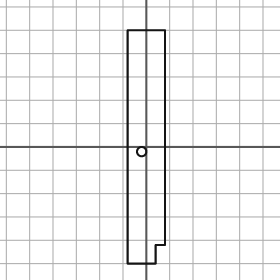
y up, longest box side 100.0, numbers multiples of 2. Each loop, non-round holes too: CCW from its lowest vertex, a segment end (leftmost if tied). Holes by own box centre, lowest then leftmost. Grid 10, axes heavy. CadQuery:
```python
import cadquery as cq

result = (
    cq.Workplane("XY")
    .moveTo(-8.0, -50.0)
    .lineTo(4.0, -50.0)
    .lineTo(4.0, -42.0)
    .lineTo(8.0, -42.0)
    .lineTo(8.0, 50.0)
    .lineTo(-8.0, 50.0)
    .close()
    .moveTo(-2.0, -2.0)
    .circle(2.0)
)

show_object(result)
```